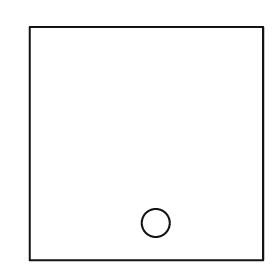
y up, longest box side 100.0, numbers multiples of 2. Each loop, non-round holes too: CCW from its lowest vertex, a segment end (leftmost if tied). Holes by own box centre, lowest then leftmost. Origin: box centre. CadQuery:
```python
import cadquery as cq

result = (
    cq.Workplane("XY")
    .moveTo(-50.0, -50.0)
    .lineTo(50.0, -50.0)
    .lineTo(50.0, 50.0)
    .lineTo(-50.0, 50.0)
    .close()
    .moveTo(4.0, -34.0)
    .circle(6.0)
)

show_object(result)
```